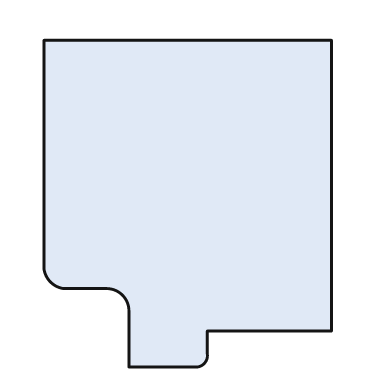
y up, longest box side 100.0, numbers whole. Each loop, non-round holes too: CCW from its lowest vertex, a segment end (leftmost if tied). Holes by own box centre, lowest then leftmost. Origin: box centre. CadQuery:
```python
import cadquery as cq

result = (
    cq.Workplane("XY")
    .moveTo(-18.0, -50.0)
    .lineTo(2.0, -50.0)
    .threePointArc((5.0, -49.0), (6.0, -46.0))
    .lineTo(6.0, -39.0)
    .lineTo(44.0, -39.0)
    .lineTo(44.0, 50.0)
    .lineTo(-44.0, 50.0)
    .lineTo(-44.0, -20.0)
    .threePointArc((-42.0, -24.0), (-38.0, -26.0))
    .lineTo(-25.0, -26.0)
    .threePointArc((-20.0, -28.0), (-18.0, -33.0))
    .close()
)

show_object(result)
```